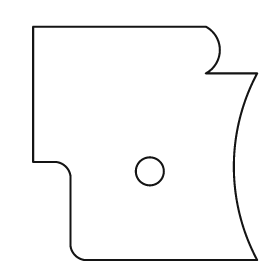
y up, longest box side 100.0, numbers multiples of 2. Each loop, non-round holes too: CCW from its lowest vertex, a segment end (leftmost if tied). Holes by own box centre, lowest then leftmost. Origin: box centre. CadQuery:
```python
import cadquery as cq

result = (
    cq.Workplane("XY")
    .moveTo(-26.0, -50.0)
    .lineTo(48.0, -50.0)
    .threePointArc((38.0, -10.0), (48.0, 30.0))
    .lineTo(26.0, 30.0)
    .threePointArc((32.0, 40.0), (26.0, 50.0))
    .lineTo(-48.0, 50.0)
    .lineTo(-48.0, -8.0)
    .lineTo(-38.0, -8.0)
    .threePointArc((-34.0, -10.0), (-32.0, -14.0))
    .lineTo(-32.0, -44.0)
    .threePointArc((-30.0, -48.0), (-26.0, -50.0))
    .close()
    .moveTo(2.0, -12.0)
    .circle(6.0)
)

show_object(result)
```